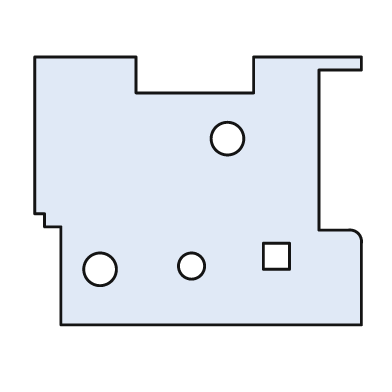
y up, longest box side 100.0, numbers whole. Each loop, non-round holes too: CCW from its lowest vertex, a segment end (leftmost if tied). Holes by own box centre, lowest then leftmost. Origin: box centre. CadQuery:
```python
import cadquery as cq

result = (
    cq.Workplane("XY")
    .moveTo(-42.0, -41.0)
    .lineTo(50.0, -41.0)
    .lineTo(50.0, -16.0)
    .threePointArc((49.0, -13.0), (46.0, -12.0))
    .lineTo(37.0, -12.0)
    .lineTo(37.0, 37.0)
    .lineTo(50.0, 37.0)
    .lineTo(50.0, 41.0)
    .lineTo(17.0, 41.0)
    .lineTo(17.0, 30.0)
    .lineTo(-19.0, 30.0)
    .lineTo(-19.0, 41.0)
    .lineTo(-50.0, 41.0)
    .lineTo(-50.0, -7.0)
    .lineTo(-47.0, -7.0)
    .lineTo(-47.0, -11.0)
    .lineTo(-42.0, -11.0)
    .close()
    .moveTo(-30.0, -24.0)
    .circle(5.0)
    .moveTo(-2.0, -23.0)
    .circle(4.0)
    .moveTo(20.0, -24.0)
    .lineTo(28.0, -24.0)
    .lineTo(28.0, -16.0)
    .lineTo(20.0, -16.0)
    .close()
    .moveTo(9.0, 16.0)
    .circle(5.0)
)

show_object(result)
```